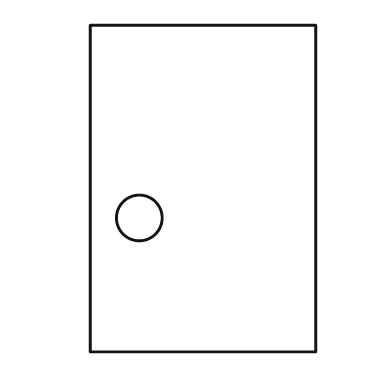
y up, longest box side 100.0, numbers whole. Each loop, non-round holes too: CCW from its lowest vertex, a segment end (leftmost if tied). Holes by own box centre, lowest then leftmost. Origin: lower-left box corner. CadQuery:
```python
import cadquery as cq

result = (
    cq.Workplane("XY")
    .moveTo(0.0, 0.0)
    .lineTo(69.0, 0.0)
    .lineTo(69.0, 100.0)
    .lineTo(0.0, 100.0)
    .close()
    .moveTo(15.0, 41.0)
    .circle(7.0)
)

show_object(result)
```